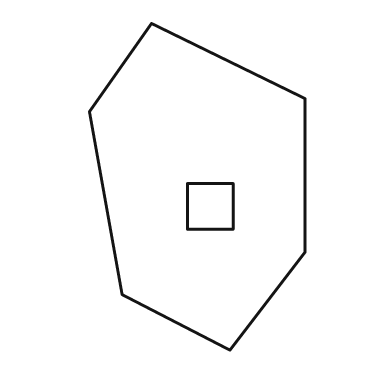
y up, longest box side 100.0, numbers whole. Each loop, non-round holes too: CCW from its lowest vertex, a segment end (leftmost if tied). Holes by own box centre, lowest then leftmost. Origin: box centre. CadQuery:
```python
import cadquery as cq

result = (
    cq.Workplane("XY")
    .moveTo(10.0, -50.0)
    .lineTo(33.0, -20.0)
    .lineTo(33.0, 27.0)
    .lineTo(-14.0, 50.0)
    .lineTo(-33.0, 23.0)
    .lineTo(-23.0, -33.0)
    .close()
    .moveTo(-3.0, -13.0)
    .lineTo(11.0, -13.0)
    .lineTo(11.0, 1.0)
    .lineTo(-3.0, 1.0)
    .close()
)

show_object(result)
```